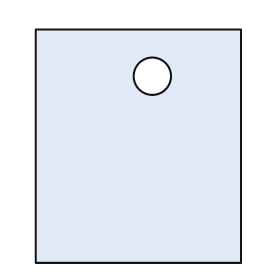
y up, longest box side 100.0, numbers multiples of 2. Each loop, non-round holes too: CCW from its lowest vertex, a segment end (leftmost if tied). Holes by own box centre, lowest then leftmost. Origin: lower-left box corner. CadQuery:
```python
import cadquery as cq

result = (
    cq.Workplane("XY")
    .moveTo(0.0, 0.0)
    .lineTo(88.0, 0.0)
    .lineTo(88.0, 100.0)
    .lineTo(0.0, 100.0)
    .close()
    .moveTo(50.0, 80.0)
    .circle(8.0)
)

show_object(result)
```